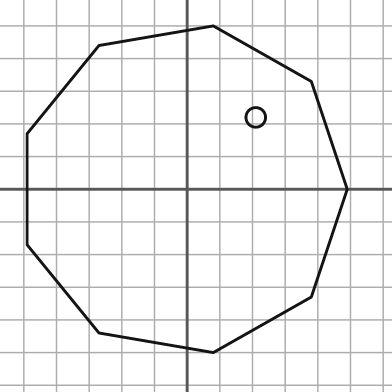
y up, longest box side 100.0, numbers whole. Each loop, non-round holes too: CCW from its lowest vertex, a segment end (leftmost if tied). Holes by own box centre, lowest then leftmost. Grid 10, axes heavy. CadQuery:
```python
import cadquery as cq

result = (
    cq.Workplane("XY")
    .moveTo(8.0, -50.0)
    .lineTo(38.0, -33.0)
    .lineTo(49.0, 0.0)
    .lineTo(38.0, 33.0)
    .lineTo(8.0, 50.0)
    .lineTo(-27.0, 44.0)
    .lineTo(-49.0, 17.0)
    .lineTo(-49.0, -17.0)
    .lineTo(-27.0, -44.0)
    .close()
    .moveTo(21.0, 22.0)
    .circle(3.0)
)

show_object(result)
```